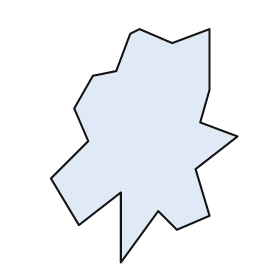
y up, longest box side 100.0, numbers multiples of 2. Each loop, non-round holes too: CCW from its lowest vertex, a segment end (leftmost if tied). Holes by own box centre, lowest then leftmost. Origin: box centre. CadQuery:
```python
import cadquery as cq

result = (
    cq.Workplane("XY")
    .moveTo(-10.0, -50.0)
    .lineTo(6.0, -28.0)
    .lineTo(14.0, -36.0)
    .lineTo(28.0, -30.0)
    .lineTo(22.0, -10.0)
    .lineTo(40.0, 4.0)
    .lineTo(24.0, 10.0)
    .lineTo(28.0, 24.0)
    .lineTo(28.0, 50.0)
    .lineTo(12.0, 44.0)
    .lineTo(-2.0, 50.0)
    .lineTo(-6.0, 48.0)
    .lineTo(-12.0, 32.0)
    .lineTo(-22.0, 30.0)
    .lineTo(-30.0, 16.0)
    .lineTo(-24.0, 2.0)
    .lineTo(-40.0, -14.0)
    .lineTo(-28.0, -34.0)
    .lineTo(-10.0, -20.0)
    .close()
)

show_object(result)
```